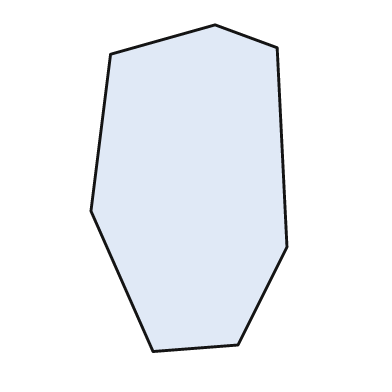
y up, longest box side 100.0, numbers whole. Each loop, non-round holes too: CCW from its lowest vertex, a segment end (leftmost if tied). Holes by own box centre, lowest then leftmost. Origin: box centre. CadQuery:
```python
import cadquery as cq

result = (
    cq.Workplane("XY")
    .moveTo(-11.0, -50.0)
    .lineTo(15.0, -48.0)
    .lineTo(30.0, -18.0)
    .lineTo(27.0, 43.0)
    .lineTo(8.0, 50.0)
    .lineTo(-24.0, 41.0)
    .lineTo(-30.0, -7.0)
    .close()
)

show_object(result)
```